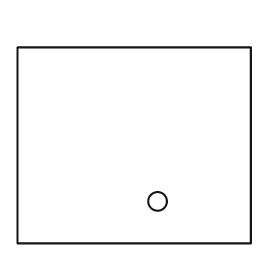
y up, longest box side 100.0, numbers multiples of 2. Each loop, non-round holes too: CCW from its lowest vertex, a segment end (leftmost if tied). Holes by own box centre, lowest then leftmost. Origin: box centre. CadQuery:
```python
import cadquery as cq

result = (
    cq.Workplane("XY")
    .moveTo(-50.0, -42.0)
    .lineTo(50.0, -42.0)
    .lineTo(50.0, 42.0)
    .lineTo(-50.0, 42.0)
    .close()
    .moveTo(10.0, -24.0)
    .circle(4.0)
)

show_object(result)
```